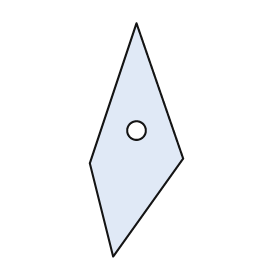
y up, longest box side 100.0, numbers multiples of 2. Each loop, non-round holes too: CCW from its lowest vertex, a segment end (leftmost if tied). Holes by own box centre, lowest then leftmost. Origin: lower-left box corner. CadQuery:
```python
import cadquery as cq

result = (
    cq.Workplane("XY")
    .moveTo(10.0, 0.0)
    .lineTo(40.0, 42.0)
    .lineTo(20.0, 100.0)
    .lineTo(0.0, 40.0)
    .close()
    .moveTo(20.0, 54.0)
    .circle(4.0)
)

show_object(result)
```